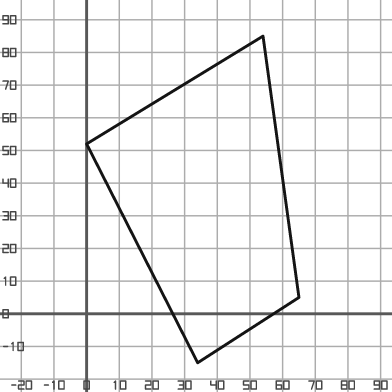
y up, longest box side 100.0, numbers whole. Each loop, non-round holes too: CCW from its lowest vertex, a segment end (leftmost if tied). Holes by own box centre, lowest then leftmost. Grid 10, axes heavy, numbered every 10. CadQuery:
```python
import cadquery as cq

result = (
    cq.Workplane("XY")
    .moveTo(34.0, -15.0)
    .lineTo(65.0, 5.0)
    .lineTo(54.0, 85.0)
    .lineTo(0.0, 52.0)
    .close()
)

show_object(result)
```